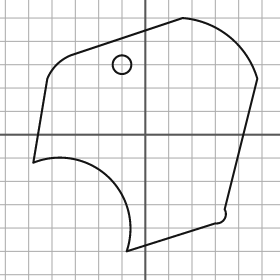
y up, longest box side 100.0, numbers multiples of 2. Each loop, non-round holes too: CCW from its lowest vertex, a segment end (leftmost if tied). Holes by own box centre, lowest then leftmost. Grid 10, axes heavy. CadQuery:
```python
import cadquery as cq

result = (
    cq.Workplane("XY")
    .moveTo(-8.0, -50.0)
    .lineTo(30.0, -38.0)
    .threePointArc((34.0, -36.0), (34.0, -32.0))
    .lineTo(48.0, 24.0)
    .threePointArc((36.0, 42.0), (16.0, 50.0))
    .lineTo(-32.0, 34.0)
    .threePointArc((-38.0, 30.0), (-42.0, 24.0))
    .lineTo(-48.0, -12.0)
    .threePointArc((-16.0, -18.0), (-8.0, -50.0))
    .close()
    .moveTo(-10.0, 30.0)
    .circle(4.0)
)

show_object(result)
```